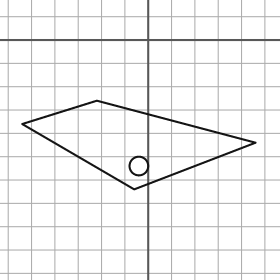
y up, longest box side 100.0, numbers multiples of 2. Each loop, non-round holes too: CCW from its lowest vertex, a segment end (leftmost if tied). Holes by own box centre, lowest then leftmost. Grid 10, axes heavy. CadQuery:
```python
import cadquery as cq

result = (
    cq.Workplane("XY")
    .moveTo(-6.0, -64.0)
    .lineTo(46.0, -44.0)
    .lineTo(-22.0, -26.0)
    .lineTo(-54.0, -36.0)
    .close()
    .moveTo(-4.0, -54.0)
    .circle(4.0)
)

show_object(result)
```